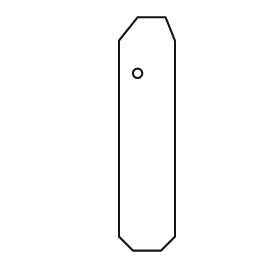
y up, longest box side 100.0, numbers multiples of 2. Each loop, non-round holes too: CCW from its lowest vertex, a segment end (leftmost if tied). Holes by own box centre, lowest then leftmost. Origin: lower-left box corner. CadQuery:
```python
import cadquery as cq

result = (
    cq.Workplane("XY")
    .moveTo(6.0, 0.0)
    .lineTo(18.0, 0.0)
    .lineTo(24.0, 6.0)
    .lineTo(24.0, 90.0)
    .lineTo(20.0, 100.0)
    .lineTo(8.0, 100.0)
    .lineTo(0.0, 90.0)
    .lineTo(0.0, 6.0)
    .close()
    .moveTo(8.0, 76.0)
    .circle(2.0)
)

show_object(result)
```